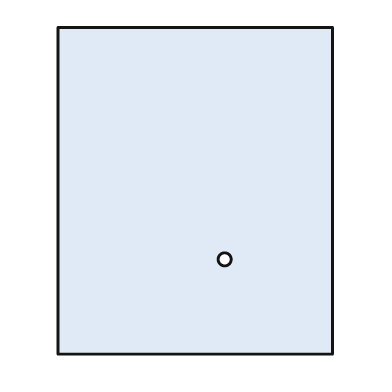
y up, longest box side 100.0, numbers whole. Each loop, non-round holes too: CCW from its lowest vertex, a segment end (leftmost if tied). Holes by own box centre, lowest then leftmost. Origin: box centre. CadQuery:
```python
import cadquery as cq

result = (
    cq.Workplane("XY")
    .moveTo(-42.0, -50.0)
    .lineTo(42.0, -50.0)
    .lineTo(42.0, 50.0)
    .lineTo(-42.0, 50.0)
    .close()
    .moveTo(9.0, -21.0)
    .circle(2.0)
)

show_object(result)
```